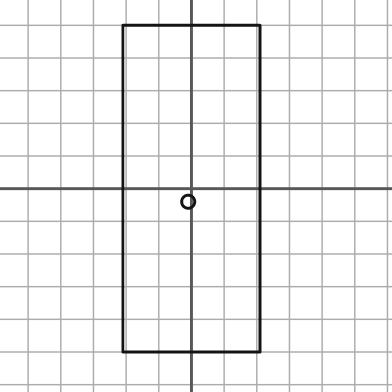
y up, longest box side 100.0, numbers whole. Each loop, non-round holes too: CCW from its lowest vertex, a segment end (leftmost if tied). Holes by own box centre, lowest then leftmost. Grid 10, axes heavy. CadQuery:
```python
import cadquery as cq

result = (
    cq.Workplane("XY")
    .moveTo(-21.0, -50.0)
    .lineTo(21.0, -50.0)
    .lineTo(21.0, 50.0)
    .lineTo(-21.0, 50.0)
    .close()
    .moveTo(-1.0, -4.0)
    .circle(2.0)
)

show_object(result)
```